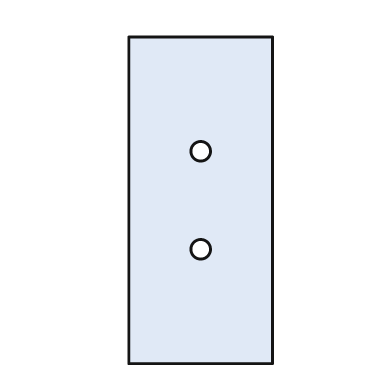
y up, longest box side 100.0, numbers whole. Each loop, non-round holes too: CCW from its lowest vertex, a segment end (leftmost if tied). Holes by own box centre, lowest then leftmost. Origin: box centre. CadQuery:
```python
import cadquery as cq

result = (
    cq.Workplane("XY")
    .moveTo(-22.0, -50.0)
    .lineTo(22.0, -50.0)
    .lineTo(22.0, 50.0)
    .lineTo(-22.0, 50.0)
    .close()
    .moveTo(0.0, -15.0)
    .circle(3.0)
    .moveTo(0.0, 15.0)
    .circle(3.0)
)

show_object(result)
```